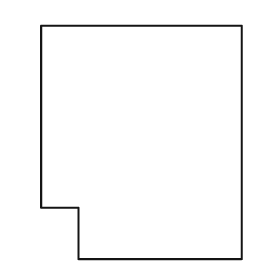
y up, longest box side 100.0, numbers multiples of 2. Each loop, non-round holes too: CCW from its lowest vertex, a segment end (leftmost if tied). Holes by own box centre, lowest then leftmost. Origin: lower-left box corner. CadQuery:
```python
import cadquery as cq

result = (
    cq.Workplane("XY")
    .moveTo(16.0, 0.0)
    .lineTo(86.0, 0.0)
    .lineTo(86.0, 100.0)
    .lineTo(0.0, 100.0)
    .lineTo(0.0, 22.0)
    .lineTo(16.0, 22.0)
    .close()
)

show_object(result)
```